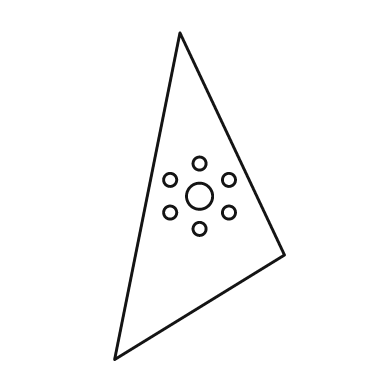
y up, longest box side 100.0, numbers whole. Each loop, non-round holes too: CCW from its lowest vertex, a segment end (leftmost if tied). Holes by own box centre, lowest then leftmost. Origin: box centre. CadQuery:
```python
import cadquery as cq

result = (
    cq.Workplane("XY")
    .moveTo(-26.0, -50.0)
    .lineTo(26.0, -18.0)
    .lineTo(-6.0, 50.0)
    .close()
    .moveTo(0.0, -10.0)
    .circle(2.0)
    .moveTo(-9.0, -5.0)
    .circle(2.0)
    .moveTo(9.0, -5.0)
    .circle(2.0)
    .moveTo(0.0, 0.0)
    .circle(4.0)
    .moveTo(-9.0, 5.0)
    .circle(2.0)
    .moveTo(9.0, 5.0)
    .circle(2.0)
    .moveTo(0.0, 10.0)
    .circle(2.0)
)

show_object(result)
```